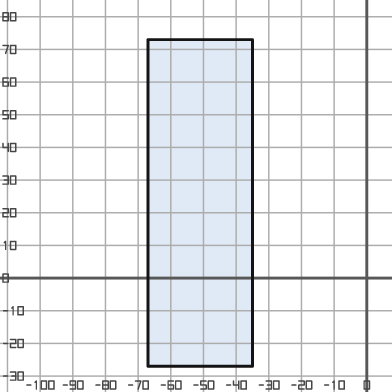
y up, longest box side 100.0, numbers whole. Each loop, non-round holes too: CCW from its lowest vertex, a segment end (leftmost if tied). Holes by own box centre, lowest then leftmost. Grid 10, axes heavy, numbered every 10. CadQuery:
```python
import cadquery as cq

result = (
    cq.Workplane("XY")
    .moveTo(-67.0, -27.0)
    .lineTo(-35.0, -27.0)
    .lineTo(-35.0, 73.0)
    .lineTo(-67.0, 73.0)
    .close()
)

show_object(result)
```